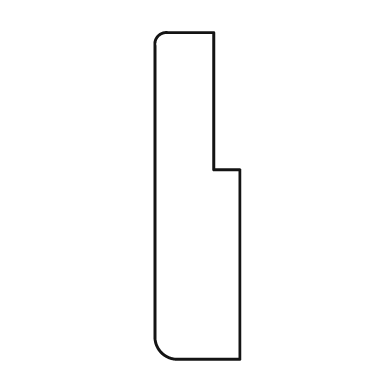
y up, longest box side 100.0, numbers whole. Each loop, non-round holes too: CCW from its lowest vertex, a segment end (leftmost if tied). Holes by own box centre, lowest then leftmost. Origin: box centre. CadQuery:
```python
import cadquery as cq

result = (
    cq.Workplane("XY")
    .moveTo(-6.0, -50.0)
    .lineTo(13.0, -50.0)
    .lineTo(13.0, 8.0)
    .lineTo(5.0, 8.0)
    .lineTo(5.0, 50.0)
    .lineTo(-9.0, 50.0)
    .threePointArc((-12.0, 49.0), (-13.0, 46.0))
    .lineTo(-13.0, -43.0)
    .threePointArc((-11.0, -48.0), (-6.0, -50.0))
    .close()
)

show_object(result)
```